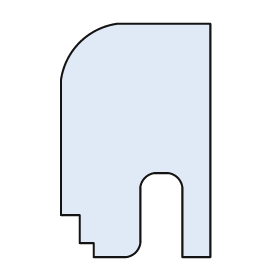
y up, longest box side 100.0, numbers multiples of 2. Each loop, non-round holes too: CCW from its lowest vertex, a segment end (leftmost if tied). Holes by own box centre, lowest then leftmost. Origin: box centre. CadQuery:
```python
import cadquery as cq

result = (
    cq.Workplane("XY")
    .moveTo(-18.0, -50.0)
    .lineTo(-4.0, -50.0)
    .threePointArc((0.0, -48.0), (2.0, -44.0))
    .lineTo(2.0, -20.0)
    .threePointArc((4.0, -16.0), (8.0, -14.0))
    .lineTo(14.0, -14.0)
    .threePointArc((18.0, -16.0), (20.0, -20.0))
    .lineTo(20.0, -50.0)
    .lineTo(32.0, -50.0)
    .lineTo(32.0, 50.0)
    .lineTo(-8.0, 50.0)
    .threePointArc((-24.0, 42.0), (-32.0, 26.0))
    .lineTo(-32.0, -32.0)
    .lineTo(-24.0, -32.0)
    .lineTo(-24.0, -44.0)
    .lineTo(-18.0, -44.0)
    .close()
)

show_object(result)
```